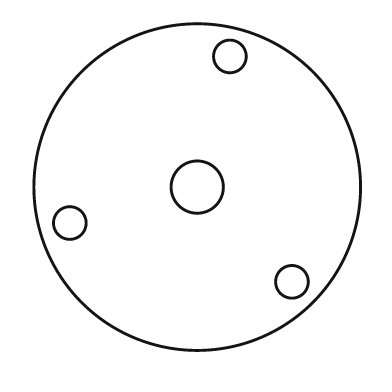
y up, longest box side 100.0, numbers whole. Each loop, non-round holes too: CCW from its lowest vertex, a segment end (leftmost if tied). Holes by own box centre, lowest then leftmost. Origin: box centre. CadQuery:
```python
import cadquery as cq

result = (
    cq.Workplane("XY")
    .moveTo(0.0, 0.0)
    .circle(50.0)
    .moveTo(29.0, -29.0)
    .circle(5.0)
    .moveTo(-39.0, -11.0)
    .circle(5.0)
    .moveTo(0.0, 0.0)
    .circle(8.0)
    .moveTo(10.0, 40.0)
    .circle(5.0)
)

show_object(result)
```